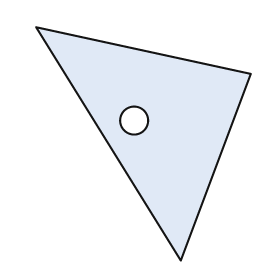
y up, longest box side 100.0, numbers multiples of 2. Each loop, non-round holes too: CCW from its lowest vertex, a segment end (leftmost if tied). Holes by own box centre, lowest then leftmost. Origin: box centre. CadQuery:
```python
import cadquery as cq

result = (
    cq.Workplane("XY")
    .moveTo(16.0, -50.0)
    .lineTo(46.0, 30.0)
    .lineTo(-46.0, 50.0)
    .close()
    .moveTo(-4.0, 10.0)
    .circle(6.0)
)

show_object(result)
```